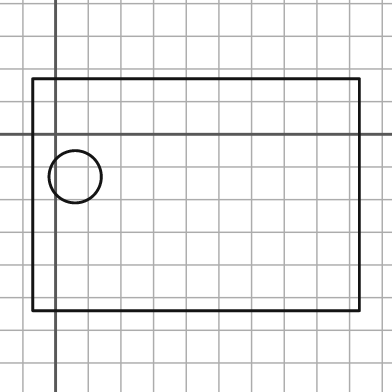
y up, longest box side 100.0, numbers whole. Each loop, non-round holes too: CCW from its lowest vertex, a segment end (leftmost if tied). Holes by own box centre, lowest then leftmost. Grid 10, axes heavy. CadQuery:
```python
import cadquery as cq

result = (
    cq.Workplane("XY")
    .moveTo(-7.0, -54.0)
    .lineTo(93.0, -54.0)
    .lineTo(93.0, 17.0)
    .lineTo(-7.0, 17.0)
    .close()
    .moveTo(6.0, -13.0)
    .circle(8.0)
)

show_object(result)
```